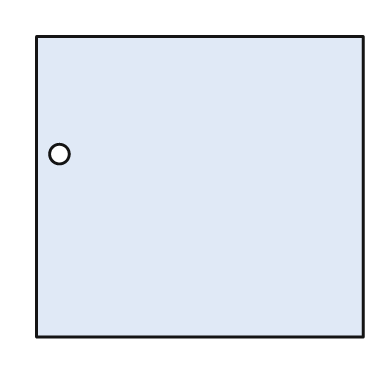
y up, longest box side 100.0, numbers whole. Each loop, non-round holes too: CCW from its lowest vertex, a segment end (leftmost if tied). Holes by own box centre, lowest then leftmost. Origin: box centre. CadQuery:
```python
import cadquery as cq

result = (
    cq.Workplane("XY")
    .moveTo(-50.0, -46.0)
    .lineTo(50.0, -46.0)
    .lineTo(50.0, 46.0)
    .lineTo(-50.0, 46.0)
    .close()
    .moveTo(-43.0, 10.0)
    .circle(3.0)
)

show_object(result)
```